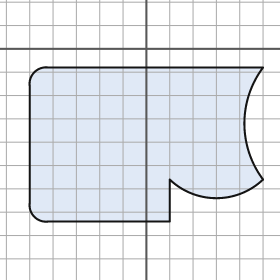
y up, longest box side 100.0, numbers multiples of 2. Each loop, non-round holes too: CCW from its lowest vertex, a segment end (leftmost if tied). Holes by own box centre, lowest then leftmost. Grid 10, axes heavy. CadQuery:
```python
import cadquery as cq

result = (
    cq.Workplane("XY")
    .moveTo(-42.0, -74.0)
    .lineTo(10.0, -74.0)
    .lineTo(10.0, -56.0)
    .threePointArc((30.0, -64.0), (50.0, -56.0))
    .threePointArc((42.0, -32.0), (50.0, -8.0))
    .lineTo(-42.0, -8.0)
    .threePointArc((-48.0, -10.0), (-50.0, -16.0))
    .lineTo(-50.0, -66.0)
    .threePointArc((-48.0, -72.0), (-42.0, -74.0))
    .close()
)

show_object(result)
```